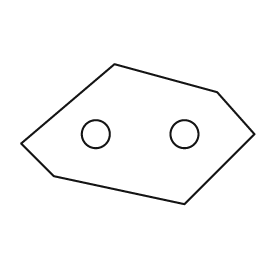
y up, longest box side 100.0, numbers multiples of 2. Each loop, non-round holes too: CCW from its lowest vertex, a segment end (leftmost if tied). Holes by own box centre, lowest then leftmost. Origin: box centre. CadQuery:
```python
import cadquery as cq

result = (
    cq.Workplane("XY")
    .moveTo(20.0, -30.0)
    .lineTo(50.0, 0.0)
    .lineTo(34.0, 18.0)
    .lineTo(-10.0, 30.0)
    .lineTo(-50.0, -4.0)
    .lineTo(-36.0, -18.0)
    .close()
    .moveTo(-18.0, 0.0)
    .circle(6.0)
    .moveTo(20.0, 0.0)
    .circle(6.0)
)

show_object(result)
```